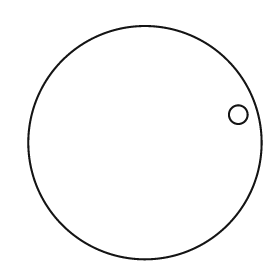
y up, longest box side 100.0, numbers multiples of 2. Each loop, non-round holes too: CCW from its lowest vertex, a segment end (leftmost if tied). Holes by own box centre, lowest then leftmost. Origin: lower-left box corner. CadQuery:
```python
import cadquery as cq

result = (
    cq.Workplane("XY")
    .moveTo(50.0, 50.0)
    .circle(50.0)
    .moveTo(90.0, 62.0)
    .circle(4.0)
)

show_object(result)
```